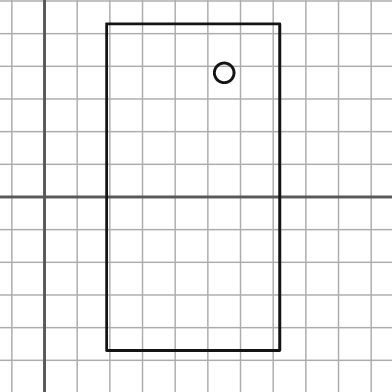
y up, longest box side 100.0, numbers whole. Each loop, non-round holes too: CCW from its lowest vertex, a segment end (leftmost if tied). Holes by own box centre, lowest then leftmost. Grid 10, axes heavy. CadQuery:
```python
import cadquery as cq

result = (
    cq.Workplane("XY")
    .moveTo(19.0, -47.0)
    .lineTo(72.0, -47.0)
    .lineTo(72.0, 53.0)
    .lineTo(19.0, 53.0)
    .close()
    .moveTo(55.0, 38.0)
    .circle(3.0)
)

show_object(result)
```